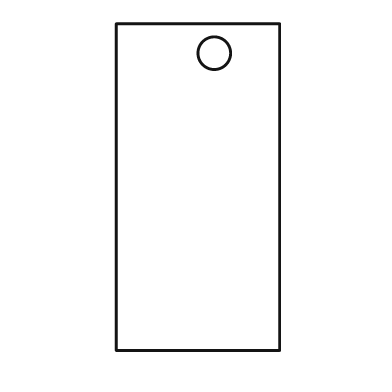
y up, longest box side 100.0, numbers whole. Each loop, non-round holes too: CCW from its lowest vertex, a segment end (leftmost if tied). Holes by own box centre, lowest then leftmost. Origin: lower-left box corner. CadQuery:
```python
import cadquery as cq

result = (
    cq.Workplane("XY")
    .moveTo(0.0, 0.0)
    .lineTo(50.0, 0.0)
    .lineTo(50.0, 100.0)
    .lineTo(0.0, 100.0)
    .close()
    .moveTo(30.0, 91.0)
    .circle(5.0)
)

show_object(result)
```